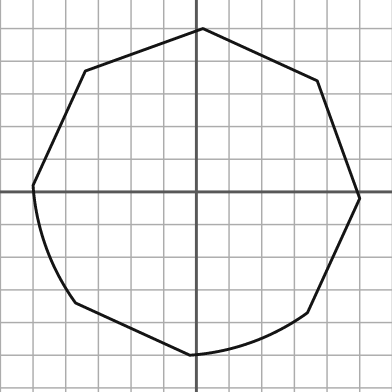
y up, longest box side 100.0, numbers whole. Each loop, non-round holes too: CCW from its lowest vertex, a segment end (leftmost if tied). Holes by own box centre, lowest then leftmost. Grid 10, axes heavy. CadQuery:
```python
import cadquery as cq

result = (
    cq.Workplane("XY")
    .moveTo(-2.0, -50.0)
    .threePointArc((17.0, -46.0), (34.0, -37.0))
    .lineTo(50.0, -2.0)
    .lineTo(37.0, 34.0)
    .lineTo(2.0, 50.0)
    .lineTo(-34.0, 37.0)
    .lineTo(-50.0, 2.0)
    .threePointArc((-46.0, -17.0), (-37.0, -34.0))
    .close()
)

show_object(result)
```